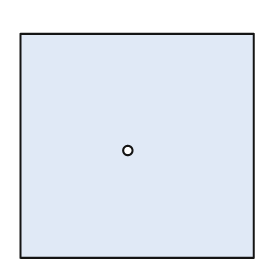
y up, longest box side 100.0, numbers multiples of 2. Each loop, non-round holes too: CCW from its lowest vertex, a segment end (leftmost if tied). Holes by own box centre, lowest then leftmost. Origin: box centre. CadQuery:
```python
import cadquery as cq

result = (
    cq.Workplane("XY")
    .moveTo(-50.0, -48.0)
    .lineTo(50.0, -48.0)
    .lineTo(50.0, 48.0)
    .lineTo(-50.0, 48.0)
    .close()
    .moveTo(-4.0, -2.0)
    .circle(2.0)
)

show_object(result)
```